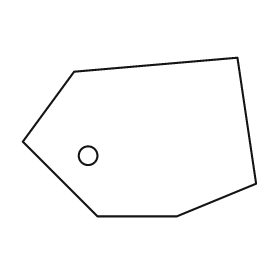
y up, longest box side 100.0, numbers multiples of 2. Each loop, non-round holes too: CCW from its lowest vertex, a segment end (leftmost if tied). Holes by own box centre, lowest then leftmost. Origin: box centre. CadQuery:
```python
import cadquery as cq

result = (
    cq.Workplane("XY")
    .moveTo(-18.0, -34.0)
    .lineTo(16.0, -34.0)
    .lineTo(50.0, -20.0)
    .lineTo(42.0, 34.0)
    .lineTo(-28.0, 28.0)
    .lineTo(-50.0, -2.0)
    .close()
    .moveTo(-22.0, -8.0)
    .circle(4.0)
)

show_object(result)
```